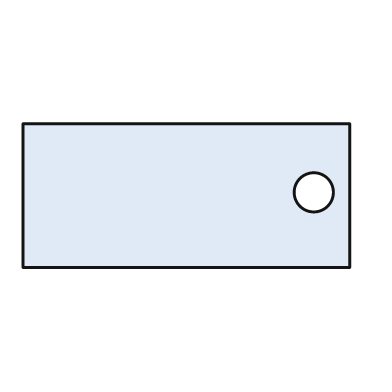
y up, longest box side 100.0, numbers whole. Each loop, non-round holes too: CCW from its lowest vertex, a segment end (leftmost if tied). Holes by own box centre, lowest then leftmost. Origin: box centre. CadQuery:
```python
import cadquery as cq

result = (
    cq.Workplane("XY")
    .moveTo(-50.0, -22.0)
    .lineTo(50.0, -22.0)
    .lineTo(50.0, 22.0)
    .lineTo(-50.0, 22.0)
    .close()
    .moveTo(39.0, 1.0)
    .circle(6.0)
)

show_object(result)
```